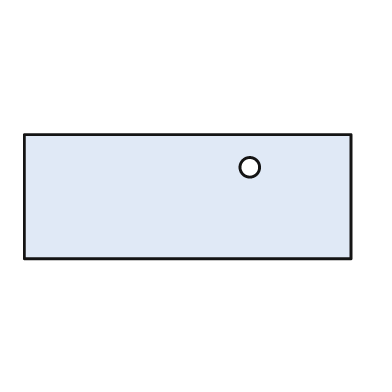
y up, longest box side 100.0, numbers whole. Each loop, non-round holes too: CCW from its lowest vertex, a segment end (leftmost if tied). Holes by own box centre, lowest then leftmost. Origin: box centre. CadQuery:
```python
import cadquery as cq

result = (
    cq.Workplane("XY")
    .moveTo(-50.0, -19.0)
    .lineTo(50.0, -19.0)
    .lineTo(50.0, 19.0)
    .lineTo(-50.0, 19.0)
    .close()
    .moveTo(19.0, 9.0)
    .circle(3.0)
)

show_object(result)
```